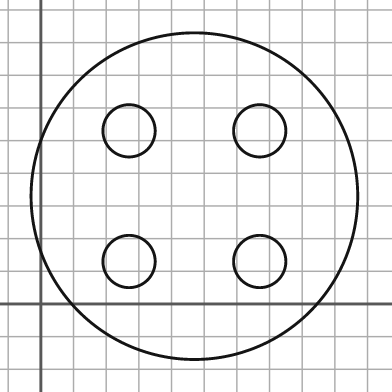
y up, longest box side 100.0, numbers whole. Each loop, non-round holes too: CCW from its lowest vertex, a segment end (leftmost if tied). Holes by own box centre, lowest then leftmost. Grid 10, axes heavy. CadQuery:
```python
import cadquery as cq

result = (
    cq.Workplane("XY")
    .moveTo(47.0, 33.0)
    .circle(50.0)
    .moveTo(27.0, 13.0)
    .circle(8.0)
    .moveTo(67.0, 13.0)
    .circle(8.0)
    .moveTo(27.0, 53.0)
    .circle(8.0)
    .moveTo(67.0, 53.0)
    .circle(8.0)
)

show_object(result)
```